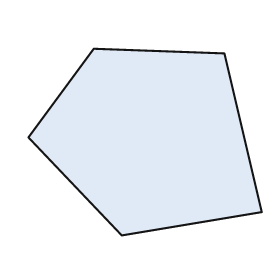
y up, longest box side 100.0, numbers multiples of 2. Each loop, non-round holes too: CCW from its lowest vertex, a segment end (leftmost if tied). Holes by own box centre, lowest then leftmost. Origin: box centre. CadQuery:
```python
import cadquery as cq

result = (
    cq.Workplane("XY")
    .moveTo(-10.0, -40.0)
    .lineTo(50.0, -30.0)
    .lineTo(34.0, 38.0)
    .lineTo(-22.0, 40.0)
    .lineTo(-50.0, 2.0)
    .close()
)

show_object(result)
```